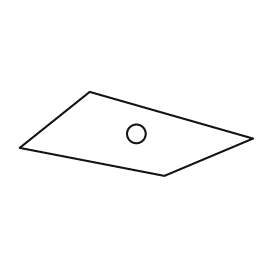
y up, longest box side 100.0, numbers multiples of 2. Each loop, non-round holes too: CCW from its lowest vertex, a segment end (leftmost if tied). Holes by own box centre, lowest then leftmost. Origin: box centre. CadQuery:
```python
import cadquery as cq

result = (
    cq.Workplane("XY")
    .moveTo(12.0, -18.0)
    .lineTo(50.0, -2.0)
    .lineTo(-20.0, 18.0)
    .lineTo(-50.0, -6.0)
    .close()
    .moveTo(0.0, 0.0)
    .circle(4.0)
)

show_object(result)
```